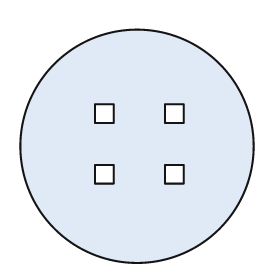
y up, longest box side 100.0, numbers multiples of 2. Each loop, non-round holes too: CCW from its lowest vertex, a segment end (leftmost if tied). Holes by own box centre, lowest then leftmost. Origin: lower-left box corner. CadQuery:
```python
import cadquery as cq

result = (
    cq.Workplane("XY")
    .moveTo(50.0, 50.0)
    .circle(50.0)
    .moveTo(32.0, 34.0)
    .lineTo(40.0, 34.0)
    .lineTo(40.0, 42.0)
    .lineTo(32.0, 42.0)
    .close()
    .moveTo(62.0, 34.0)
    .lineTo(70.0, 34.0)
    .lineTo(70.0, 42.0)
    .lineTo(62.0, 42.0)
    .close()
    .moveTo(32.0, 60.0)
    .lineTo(40.0, 60.0)
    .lineTo(40.0, 68.0)
    .lineTo(32.0, 68.0)
    .close()
    .moveTo(62.0, 60.0)
    .lineTo(70.0, 60.0)
    .lineTo(70.0, 68.0)
    .lineTo(62.0, 68.0)
    .close()
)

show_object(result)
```